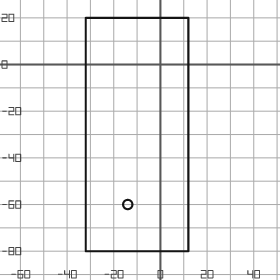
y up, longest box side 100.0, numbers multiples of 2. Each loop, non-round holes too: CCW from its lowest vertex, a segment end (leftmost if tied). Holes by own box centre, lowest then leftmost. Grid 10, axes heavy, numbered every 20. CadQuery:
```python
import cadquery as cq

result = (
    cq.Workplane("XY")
    .moveTo(-32.0, -80.0)
    .lineTo(12.0, -80.0)
    .lineTo(12.0, 20.0)
    .lineTo(-32.0, 20.0)
    .close()
    .moveTo(-14.0, -60.0)
    .circle(2.0)
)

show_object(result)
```